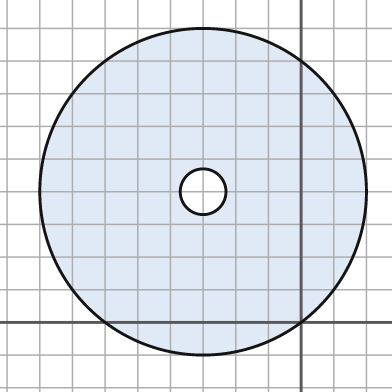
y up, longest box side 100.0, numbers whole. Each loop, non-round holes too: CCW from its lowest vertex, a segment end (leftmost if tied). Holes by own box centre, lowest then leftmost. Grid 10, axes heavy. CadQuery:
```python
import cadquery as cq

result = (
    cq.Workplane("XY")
    .moveTo(-30.0, 40.0)
    .circle(50.0)
    .moveTo(-30.0, 40.0)
    .circle(7.0)
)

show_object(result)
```